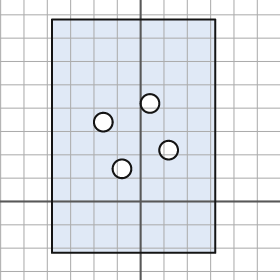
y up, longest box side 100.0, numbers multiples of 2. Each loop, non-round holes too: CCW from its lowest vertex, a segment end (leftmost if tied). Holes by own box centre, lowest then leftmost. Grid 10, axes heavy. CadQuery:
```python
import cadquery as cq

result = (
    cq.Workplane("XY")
    .moveTo(-38.0, -22.0)
    .lineTo(32.0, -22.0)
    .lineTo(32.0, 78.0)
    .lineTo(-38.0, 78.0)
    .close()
    .moveTo(-8.0, 14.0)
    .circle(4.0)
    .moveTo(12.0, 22.0)
    .circle(4.0)
    .moveTo(-16.0, 34.0)
    .circle(4.0)
    .moveTo(4.0, 42.0)
    .circle(4.0)
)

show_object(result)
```